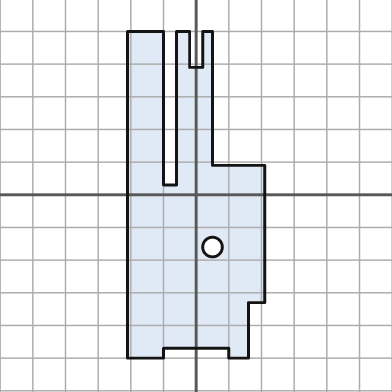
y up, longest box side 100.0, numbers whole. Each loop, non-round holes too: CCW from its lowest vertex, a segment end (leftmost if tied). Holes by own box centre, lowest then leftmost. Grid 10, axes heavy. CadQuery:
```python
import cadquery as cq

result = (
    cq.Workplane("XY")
    .moveTo(-21.0, -50.0)
    .lineTo(-10.0, -50.0)
    .lineTo(-10.0, -47.0)
    .lineTo(10.0, -47.0)
    .lineTo(10.0, -50.0)
    .lineTo(16.0, -50.0)
    .lineTo(16.0, -33.0)
    .lineTo(21.0, -33.0)
    .lineTo(21.0, 9.0)
    .lineTo(5.0, 9.0)
    .lineTo(5.0, 50.0)
    .lineTo(2.0, 50.0)
    .lineTo(2.0, 39.0)
    .lineTo(-2.0, 39.0)
    .lineTo(-2.0, 50.0)
    .lineTo(-6.0, 50.0)
    .lineTo(-6.0, 3.0)
    .lineTo(-10.0, 3.0)
    .lineTo(-10.0, 50.0)
    .lineTo(-21.0, 50.0)
    .close()
    .moveTo(5.0, -16.0)
    .circle(3.0)
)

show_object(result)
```